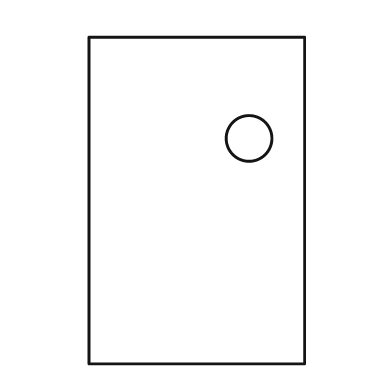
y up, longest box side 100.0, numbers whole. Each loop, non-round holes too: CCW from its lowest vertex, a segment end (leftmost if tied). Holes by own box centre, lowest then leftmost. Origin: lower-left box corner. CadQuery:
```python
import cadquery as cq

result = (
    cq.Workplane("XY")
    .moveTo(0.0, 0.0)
    .lineTo(66.0, 0.0)
    .lineTo(66.0, 100.0)
    .lineTo(0.0, 100.0)
    .close()
    .moveTo(49.0, 69.0)
    .circle(7.0)
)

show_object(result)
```